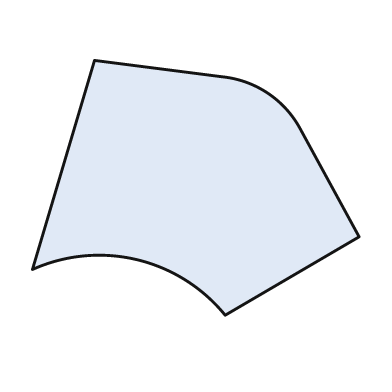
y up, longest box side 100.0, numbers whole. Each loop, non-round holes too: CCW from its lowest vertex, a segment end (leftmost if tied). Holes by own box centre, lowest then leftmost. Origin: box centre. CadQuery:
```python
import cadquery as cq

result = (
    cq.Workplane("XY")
    .moveTo(9.0, -39.0)
    .lineTo(50.0, -15.0)
    .lineTo(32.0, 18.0)
    .threePointArc((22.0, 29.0), (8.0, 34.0))
    .lineTo(-31.0, 39.0)
    .lineTo(-50.0, -25.0)
    .threePointArc((-18.0, -22.0), (9.0, -39.0))
    .close()
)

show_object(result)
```